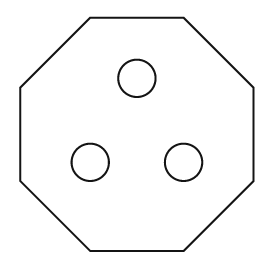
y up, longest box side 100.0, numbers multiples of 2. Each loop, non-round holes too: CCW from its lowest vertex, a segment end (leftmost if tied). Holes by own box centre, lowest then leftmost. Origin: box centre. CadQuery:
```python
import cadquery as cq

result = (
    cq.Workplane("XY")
    .moveTo(-20.0, -50.0)
    .lineTo(20.0, -50.0)
    .lineTo(50.0, -20.0)
    .lineTo(50.0, 20.0)
    .lineTo(20.0, 50.0)
    .lineTo(-20.0, 50.0)
    .lineTo(-50.0, 20.0)
    .lineTo(-50.0, -20.0)
    .close()
    .moveTo(-20.0, -12.0)
    .circle(8.0)
    .moveTo(20.0, -12.0)
    .circle(8.0)
    .moveTo(0.0, 24.0)
    .circle(8.0)
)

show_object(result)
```